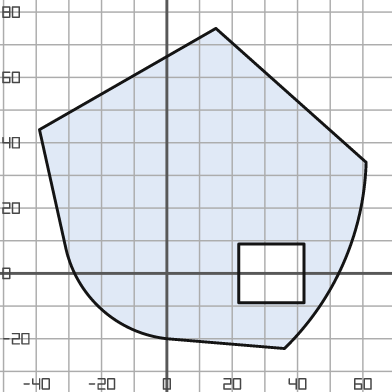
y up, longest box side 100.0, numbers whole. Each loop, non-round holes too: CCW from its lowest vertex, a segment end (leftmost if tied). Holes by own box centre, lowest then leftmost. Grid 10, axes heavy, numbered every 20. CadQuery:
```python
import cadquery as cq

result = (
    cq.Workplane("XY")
    .moveTo(36.0, -23.0)
    .threePointArc((54.0, 3.0), (61.0, 34.0))
    .lineTo(15.0, 75.0)
    .lineTo(-39.0, 44.0)
    .lineTo(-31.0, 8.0)
    .threePointArc((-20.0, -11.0), (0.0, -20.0))
    .close()
    .moveTo(22.0, -9.0)
    .lineTo(42.0, -9.0)
    .lineTo(42.0, 9.0)
    .lineTo(22.0, 9.0)
    .close()
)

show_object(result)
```